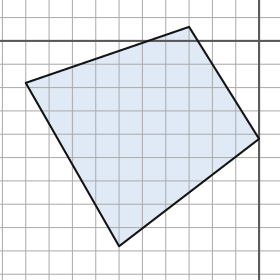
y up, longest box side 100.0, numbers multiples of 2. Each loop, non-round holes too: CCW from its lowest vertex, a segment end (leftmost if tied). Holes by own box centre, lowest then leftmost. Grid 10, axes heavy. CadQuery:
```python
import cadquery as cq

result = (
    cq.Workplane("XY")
    .moveTo(-60.0, -88.0)
    .lineTo(0.0, -42.0)
    .lineTo(-30.0, 6.0)
    .lineTo(-100.0, -18.0)
    .close()
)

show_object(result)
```